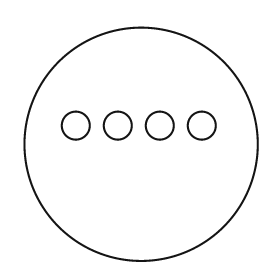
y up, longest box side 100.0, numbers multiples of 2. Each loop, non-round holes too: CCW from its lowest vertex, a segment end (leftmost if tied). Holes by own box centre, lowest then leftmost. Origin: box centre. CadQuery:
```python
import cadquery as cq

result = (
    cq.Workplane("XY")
    .moveTo(0.0, 0.0)
    .circle(50.0)
    .moveTo(-28.0, 8.0)
    .circle(6.0)
    .moveTo(-10.0, 8.0)
    .circle(6.0)
    .moveTo(8.0, 8.0)
    .circle(6.0)
    .moveTo(26.0, 8.0)
    .circle(6.0)
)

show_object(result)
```